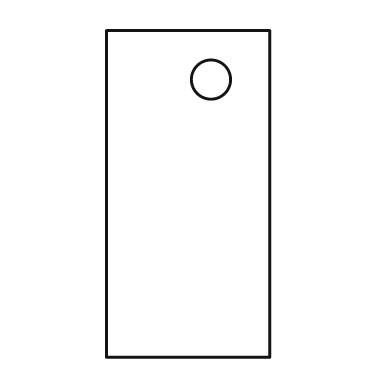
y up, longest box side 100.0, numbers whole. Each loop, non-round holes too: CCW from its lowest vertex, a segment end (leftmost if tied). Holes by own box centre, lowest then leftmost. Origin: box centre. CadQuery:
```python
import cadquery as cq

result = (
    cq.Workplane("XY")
    .moveTo(-25.0, -50.0)
    .lineTo(25.0, -50.0)
    .lineTo(25.0, 50.0)
    .lineTo(-25.0, 50.0)
    .close()
    .moveTo(7.0, 35.0)
    .circle(6.0)
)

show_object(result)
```